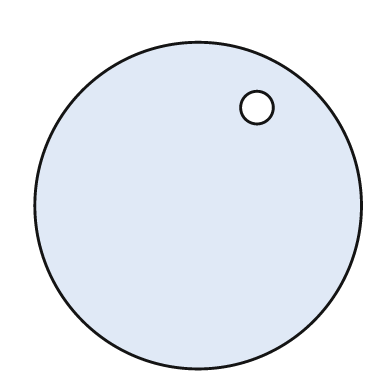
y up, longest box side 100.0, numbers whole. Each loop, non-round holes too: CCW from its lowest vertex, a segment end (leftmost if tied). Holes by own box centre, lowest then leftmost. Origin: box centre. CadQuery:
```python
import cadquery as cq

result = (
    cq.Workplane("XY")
    .moveTo(0.0, 0.0)
    .circle(50.0)
    .moveTo(18.0, 30.0)
    .circle(5.0)
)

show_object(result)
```